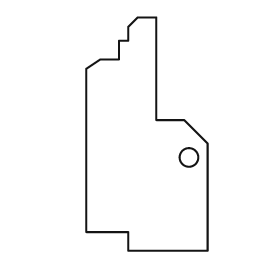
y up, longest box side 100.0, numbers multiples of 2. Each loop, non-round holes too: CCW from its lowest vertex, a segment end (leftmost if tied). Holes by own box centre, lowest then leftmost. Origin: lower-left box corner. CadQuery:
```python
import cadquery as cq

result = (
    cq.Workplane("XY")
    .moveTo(18.0, 0.0)
    .lineTo(52.0, 0.0)
    .lineTo(52.0, 46.0)
    .lineTo(42.0, 56.0)
    .lineTo(30.0, 56.0)
    .lineTo(30.0, 100.0)
    .lineTo(22.0, 100.0)
    .lineTo(18.0, 96.0)
    .lineTo(18.0, 90.0)
    .lineTo(14.0, 90.0)
    .lineTo(14.0, 82.0)
    .lineTo(6.0, 82.0)
    .lineTo(0.0, 78.0)
    .lineTo(0.0, 8.0)
    .lineTo(18.0, 8.0)
    .close()
    .moveTo(44.0, 40.0)
    .circle(4.0)
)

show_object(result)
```